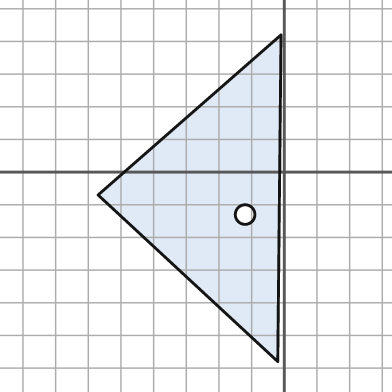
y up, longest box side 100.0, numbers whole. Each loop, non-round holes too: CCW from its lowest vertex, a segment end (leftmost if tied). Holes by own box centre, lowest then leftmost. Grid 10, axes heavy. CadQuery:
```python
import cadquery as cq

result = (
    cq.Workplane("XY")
    .moveTo(-2.0, -58.0)
    .lineTo(-1.0, 42.0)
    .lineTo(-57.0, -7.0)
    .close()
    .moveTo(-12.0, -13.0)
    .circle(3.0)
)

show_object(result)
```